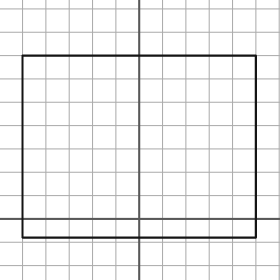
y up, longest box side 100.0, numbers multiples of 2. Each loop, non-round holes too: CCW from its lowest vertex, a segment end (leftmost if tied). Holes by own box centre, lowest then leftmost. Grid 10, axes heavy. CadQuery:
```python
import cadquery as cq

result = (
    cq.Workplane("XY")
    .moveTo(-50.0, -8.0)
    .lineTo(50.0, -8.0)
    .lineTo(50.0, 70.0)
    .lineTo(-50.0, 70.0)
    .close()
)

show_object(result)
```